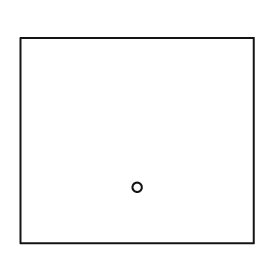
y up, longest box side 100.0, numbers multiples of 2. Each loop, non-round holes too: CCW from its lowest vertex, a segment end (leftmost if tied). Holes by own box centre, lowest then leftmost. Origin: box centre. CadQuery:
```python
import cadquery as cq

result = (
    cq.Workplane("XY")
    .moveTo(-50.0, -44.0)
    .lineTo(50.0, -44.0)
    .lineTo(50.0, 44.0)
    .lineTo(-50.0, 44.0)
    .close()
    .moveTo(0.0, -20.0)
    .circle(2.0)
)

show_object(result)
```